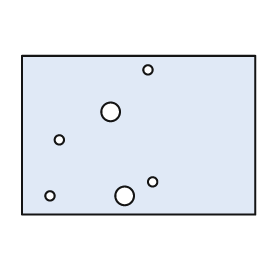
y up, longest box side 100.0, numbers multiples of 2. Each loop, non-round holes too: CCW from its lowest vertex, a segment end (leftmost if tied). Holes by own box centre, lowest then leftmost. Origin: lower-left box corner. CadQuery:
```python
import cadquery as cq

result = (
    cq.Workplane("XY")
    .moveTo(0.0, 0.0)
    .lineTo(100.0, 0.0)
    .lineTo(100.0, 68.0)
    .lineTo(0.0, 68.0)
    .close()
    .moveTo(12.0, 8.0)
    .circle(2.0)
    .moveTo(44.0, 8.0)
    .circle(4.0)
    .moveTo(56.0, 14.0)
    .circle(2.0)
    .moveTo(16.0, 32.0)
    .circle(2.0)
    .moveTo(38.0, 44.0)
    .circle(4.0)
    .moveTo(54.0, 62.0)
    .circle(2.0)
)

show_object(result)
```